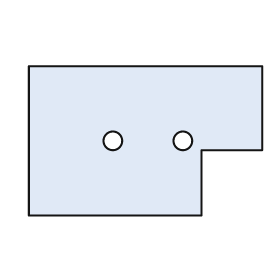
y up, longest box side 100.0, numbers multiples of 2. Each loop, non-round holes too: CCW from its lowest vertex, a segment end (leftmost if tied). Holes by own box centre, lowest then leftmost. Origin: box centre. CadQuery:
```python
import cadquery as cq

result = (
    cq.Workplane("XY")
    .moveTo(-50.0, -32.0)
    .lineTo(24.0, -32.0)
    .lineTo(24.0, -4.0)
    .lineTo(50.0, -4.0)
    .lineTo(50.0, 32.0)
    .lineTo(-50.0, 32.0)
    .close()
    .moveTo(-14.0, 0.0)
    .circle(4.0)
    .moveTo(16.0, 0.0)
    .circle(4.0)
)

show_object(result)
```